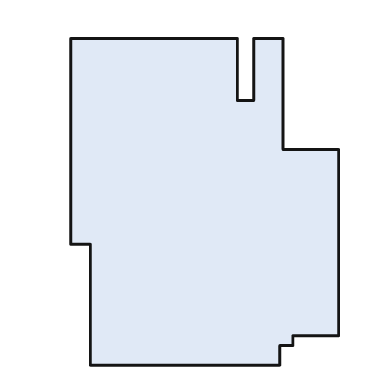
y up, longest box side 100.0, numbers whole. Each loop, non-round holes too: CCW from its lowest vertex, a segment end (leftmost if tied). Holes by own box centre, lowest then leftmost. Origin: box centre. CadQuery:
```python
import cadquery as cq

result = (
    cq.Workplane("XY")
    .moveTo(-35.0, -50.0)
    .lineTo(23.0, -50.0)
    .lineTo(23.0, -44.0)
    .lineTo(27.0, -44.0)
    .lineTo(27.0, -41.0)
    .lineTo(41.0, -41.0)
    .lineTo(41.0, 16.0)
    .lineTo(24.0, 16.0)
    .lineTo(24.0, 50.0)
    .lineTo(15.0, 50.0)
    .lineTo(15.0, 31.0)
    .lineTo(10.0, 31.0)
    .lineTo(10.0, 50.0)
    .lineTo(-41.0, 50.0)
    .lineTo(-41.0, -13.0)
    .lineTo(-35.0, -13.0)
    .close()
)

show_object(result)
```